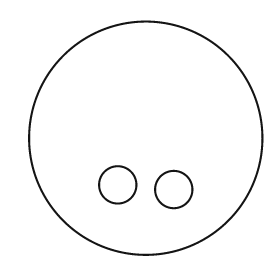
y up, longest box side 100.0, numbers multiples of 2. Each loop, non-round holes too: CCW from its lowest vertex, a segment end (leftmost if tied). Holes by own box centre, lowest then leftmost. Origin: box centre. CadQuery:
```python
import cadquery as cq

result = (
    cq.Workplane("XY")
    .moveTo(0.0, 0.0)
    .circle(50.0)
    .moveTo(12.0, -22.0)
    .circle(8.0)
    .moveTo(-12.0, -20.0)
    .circle(8.0)
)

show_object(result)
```